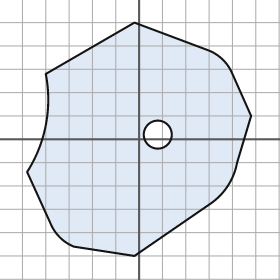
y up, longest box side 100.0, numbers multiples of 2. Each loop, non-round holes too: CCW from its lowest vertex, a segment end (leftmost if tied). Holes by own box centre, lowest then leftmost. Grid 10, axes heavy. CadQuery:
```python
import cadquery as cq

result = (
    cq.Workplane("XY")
    .moveTo(-2.0, -50.0)
    .lineTo(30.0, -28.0)
    .threePointArc((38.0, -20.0), (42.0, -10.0))
    .lineTo(48.0, 10.0)
    .lineTo(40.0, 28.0)
    .threePointArc((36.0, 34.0), (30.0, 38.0))
    .lineTo(-2.0, 50.0)
    .lineTo(-40.0, 28.0)
    .threePointArc((-40.0, 6.0), (-48.0, -14.0))
    .lineTo(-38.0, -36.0)
    .threePointArc((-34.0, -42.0), (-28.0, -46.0))
    .close()
    .moveTo(8.0, 2.0)
    .circle(6.0)
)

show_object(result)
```